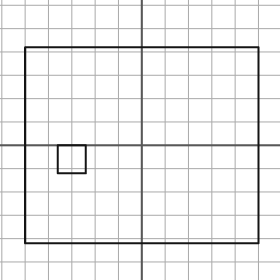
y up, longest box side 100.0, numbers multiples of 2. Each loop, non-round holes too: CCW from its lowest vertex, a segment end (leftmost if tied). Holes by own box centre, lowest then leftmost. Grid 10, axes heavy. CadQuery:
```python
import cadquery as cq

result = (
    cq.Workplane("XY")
    .moveTo(-50.0, -42.0)
    .lineTo(50.0, -42.0)
    .lineTo(50.0, 42.0)
    .lineTo(-50.0, 42.0)
    .close()
    .moveTo(-36.0, -12.0)
    .lineTo(-24.0, -12.0)
    .lineTo(-24.0, 0.0)
    .lineTo(-36.0, 0.0)
    .close()
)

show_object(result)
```